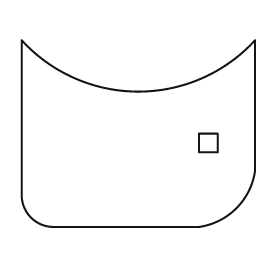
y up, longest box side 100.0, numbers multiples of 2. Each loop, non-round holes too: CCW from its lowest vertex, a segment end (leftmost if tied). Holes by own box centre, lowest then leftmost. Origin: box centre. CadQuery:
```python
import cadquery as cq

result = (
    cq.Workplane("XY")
    .moveTo(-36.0, -40.0)
    .lineTo(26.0, -40.0)
    .threePointArc((42.0, -32.0), (50.0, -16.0))
    .lineTo(50.0, 40.0)
    .threePointArc((0.0, 18.0), (-50.0, 40.0))
    .lineTo(-50.0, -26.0)
    .threePointArc((-46.0, -36.0), (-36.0, -40.0))
    .close()
    .moveTo(26.0, -8.0)
    .lineTo(34.0, -8.0)
    .lineTo(34.0, 0.0)
    .lineTo(26.0, 0.0)
    .close()
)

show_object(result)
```